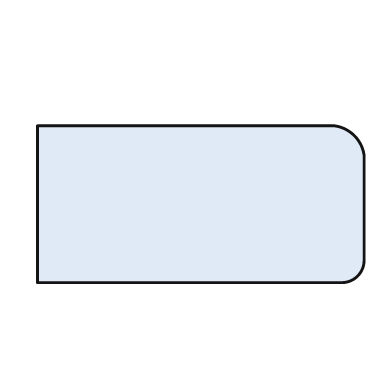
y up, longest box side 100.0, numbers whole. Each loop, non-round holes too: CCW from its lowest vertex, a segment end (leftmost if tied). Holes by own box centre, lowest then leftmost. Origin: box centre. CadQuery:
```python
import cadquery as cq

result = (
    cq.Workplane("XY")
    .moveTo(-50.0, -24.0)
    .lineTo(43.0, -24.0)
    .threePointArc((48.0, -22.0), (50.0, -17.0))
    .lineTo(50.0, 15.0)
    .threePointArc((47.0, 21.0), (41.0, 24.0))
    .lineTo(-50.0, 24.0)
    .close()
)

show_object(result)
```